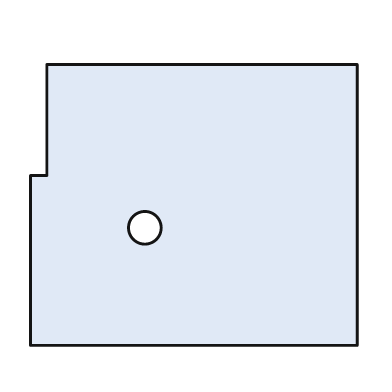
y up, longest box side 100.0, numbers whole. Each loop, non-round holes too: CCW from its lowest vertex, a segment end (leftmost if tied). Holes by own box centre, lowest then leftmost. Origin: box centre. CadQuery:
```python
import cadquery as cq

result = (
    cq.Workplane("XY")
    .moveTo(-50.0, -43.0)
    .lineTo(50.0, -43.0)
    .lineTo(50.0, 43.0)
    .lineTo(-45.0, 43.0)
    .lineTo(-45.0, 9.0)
    .lineTo(-50.0, 9.0)
    .close()
    .moveTo(-15.0, -7.0)
    .circle(5.0)
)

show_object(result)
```